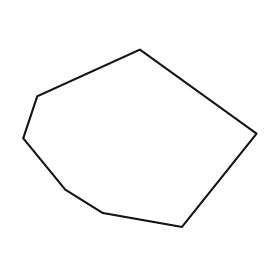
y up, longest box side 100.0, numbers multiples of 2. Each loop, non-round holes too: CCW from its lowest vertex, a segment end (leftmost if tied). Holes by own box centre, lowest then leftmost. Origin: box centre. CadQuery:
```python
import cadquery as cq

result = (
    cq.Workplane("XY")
    .moveTo(18.0, -38.0)
    .lineTo(50.0, 2.0)
    .lineTo(0.0, 38.0)
    .lineTo(-44.0, 18.0)
    .lineTo(-50.0, 0.0)
    .lineTo(-32.0, -22.0)
    .lineTo(-16.0, -32.0)
    .close()
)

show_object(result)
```